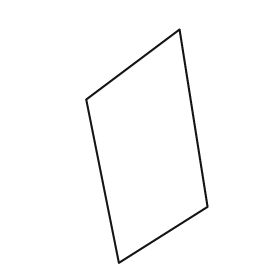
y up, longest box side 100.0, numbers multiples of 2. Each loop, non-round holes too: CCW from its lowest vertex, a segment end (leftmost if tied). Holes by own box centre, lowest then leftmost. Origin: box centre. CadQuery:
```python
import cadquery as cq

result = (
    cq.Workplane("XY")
    .moveTo(-12.0, -50.0)
    .lineTo(26.0, -26.0)
    .lineTo(14.0, 50.0)
    .lineTo(-26.0, 20.0)
    .close()
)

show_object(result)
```